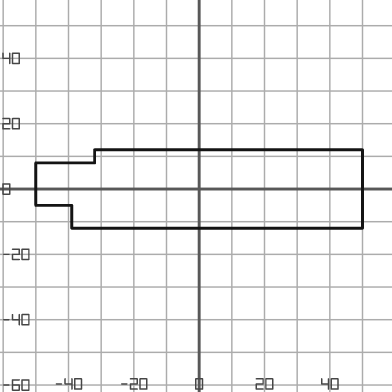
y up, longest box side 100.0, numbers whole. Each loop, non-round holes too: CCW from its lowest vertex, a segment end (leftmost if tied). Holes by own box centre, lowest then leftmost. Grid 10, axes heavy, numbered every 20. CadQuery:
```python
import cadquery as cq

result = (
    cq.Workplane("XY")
    .moveTo(-39.0, -12.0)
    .lineTo(50.0, -12.0)
    .lineTo(50.0, 12.0)
    .lineTo(-32.0, 12.0)
    .lineTo(-32.0, 8.0)
    .lineTo(-50.0, 8.0)
    .lineTo(-50.0, -5.0)
    .lineTo(-39.0, -5.0)
    .close()
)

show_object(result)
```